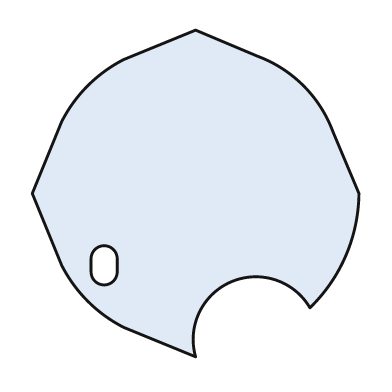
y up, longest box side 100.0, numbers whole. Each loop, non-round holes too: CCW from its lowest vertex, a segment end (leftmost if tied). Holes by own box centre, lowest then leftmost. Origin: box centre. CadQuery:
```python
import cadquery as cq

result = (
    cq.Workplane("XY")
    .moveTo(0.0, -50.0)
    .threePointArc((11.0, -27.0), (35.0, -35.0))
    .threePointArc((46.0, -19.0), (50.0, 0.0))
    .lineTo(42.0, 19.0)
    .threePointArc((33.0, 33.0), (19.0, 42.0))
    .lineTo(0.0, 50.0)
    .lineTo(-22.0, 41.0)
    .threePointArc((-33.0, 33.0), (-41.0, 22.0))
    .lineTo(-50.0, 0.0)
    .lineTo(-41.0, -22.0)
    .threePointArc((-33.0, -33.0), (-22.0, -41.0))
    .close()
    .moveTo(-32.0, -24.0)
    .threePointArc((-28.0, -28.0), (-24.0, -24.0))
    .lineTo(-24.0, -20.0)
    .threePointArc((-28.0, -16.0), (-32.0, -20.0))
    .close()
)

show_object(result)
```